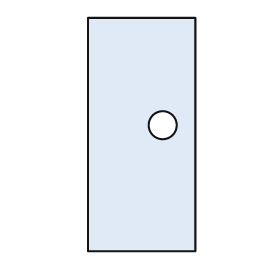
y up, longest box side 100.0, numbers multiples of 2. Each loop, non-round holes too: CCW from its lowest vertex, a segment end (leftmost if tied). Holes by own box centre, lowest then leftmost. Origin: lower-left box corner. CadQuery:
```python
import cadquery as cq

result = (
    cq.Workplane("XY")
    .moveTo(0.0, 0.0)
    .lineTo(46.0, 0.0)
    .lineTo(46.0, 100.0)
    .lineTo(0.0, 100.0)
    .close()
    .moveTo(32.0, 54.0)
    .circle(6.0)
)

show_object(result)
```